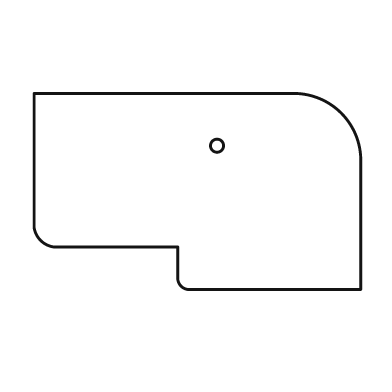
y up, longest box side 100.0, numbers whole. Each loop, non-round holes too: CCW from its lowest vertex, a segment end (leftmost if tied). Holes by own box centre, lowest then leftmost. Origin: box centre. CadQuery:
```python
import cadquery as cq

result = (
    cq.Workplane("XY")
    .moveTo(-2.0, -30.0)
    .lineTo(50.0, -30.0)
    .lineTo(50.0, 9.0)
    .threePointArc((44.0, 24.0), (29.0, 30.0))
    .lineTo(-50.0, 30.0)
    .lineTo(-50.0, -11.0)
    .threePointArc((-48.0, -15.0), (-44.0, -17.0))
    .lineTo(-6.0, -17.0)
    .lineTo(-6.0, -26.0)
    .threePointArc((-5.0, -29.0), (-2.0, -30.0))
    .close()
    .moveTo(6.0, 14.0)
    .circle(2.0)
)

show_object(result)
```